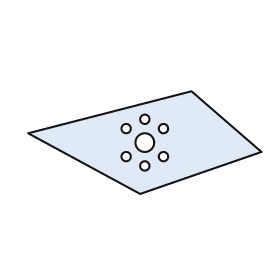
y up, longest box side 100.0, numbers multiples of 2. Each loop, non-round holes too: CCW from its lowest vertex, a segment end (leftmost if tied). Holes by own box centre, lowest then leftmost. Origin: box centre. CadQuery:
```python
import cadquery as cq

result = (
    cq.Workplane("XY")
    .moveTo(-2.0, -22.0)
    .lineTo(50.0, -4.0)
    .lineTo(20.0, 22.0)
    .lineTo(-50.0, 4.0)
    .close()
    .moveTo(0.0, -10.0)
    .circle(2.0)
    .moveTo(-8.0, -6.0)
    .circle(2.0)
    .moveTo(8.0, -6.0)
    .circle(2.0)
    .moveTo(0.0, 0.0)
    .circle(4.0)
    .moveTo(-8.0, 6.0)
    .circle(2.0)
    .moveTo(8.0, 6.0)
    .circle(2.0)
    .moveTo(0.0, 10.0)
    .circle(2.0)
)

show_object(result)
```